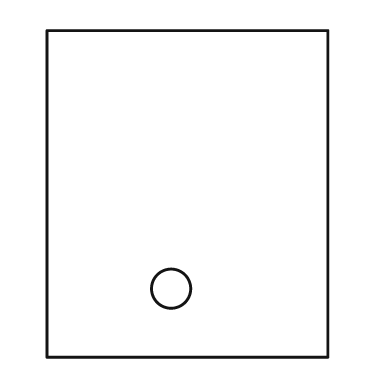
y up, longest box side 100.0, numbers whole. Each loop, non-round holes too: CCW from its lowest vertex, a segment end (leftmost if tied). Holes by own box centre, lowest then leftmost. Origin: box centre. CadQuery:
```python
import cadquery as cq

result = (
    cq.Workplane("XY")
    .moveTo(-43.0, -50.0)
    .lineTo(43.0, -50.0)
    .lineTo(43.0, 50.0)
    .lineTo(-43.0, 50.0)
    .close()
    .moveTo(-5.0, -29.0)
    .circle(6.0)
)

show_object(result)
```